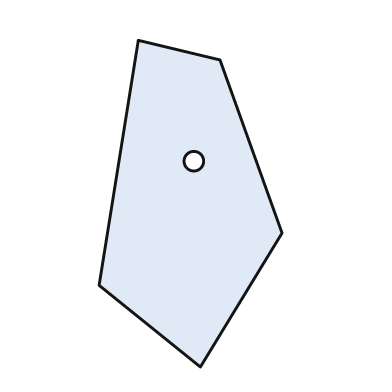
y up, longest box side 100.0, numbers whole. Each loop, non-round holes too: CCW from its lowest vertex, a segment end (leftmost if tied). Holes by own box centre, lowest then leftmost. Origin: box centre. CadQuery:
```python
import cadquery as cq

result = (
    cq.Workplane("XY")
    .moveTo(3.0, -50.0)
    .lineTo(28.0, -9.0)
    .lineTo(9.0, 44.0)
    .lineTo(-16.0, 50.0)
    .lineTo(-28.0, -25.0)
    .close()
    .moveTo(1.0, 13.0)
    .circle(3.0)
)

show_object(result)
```